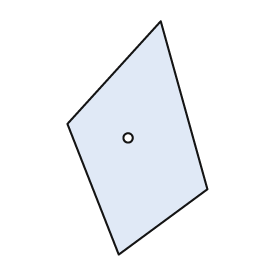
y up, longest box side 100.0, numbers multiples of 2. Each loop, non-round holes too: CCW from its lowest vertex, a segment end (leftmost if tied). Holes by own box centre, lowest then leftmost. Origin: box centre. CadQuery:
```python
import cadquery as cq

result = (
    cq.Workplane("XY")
    .moveTo(-8.0, -50.0)
    .lineTo(30.0, -22.0)
    .lineTo(10.0, 50.0)
    .lineTo(-30.0, 6.0)
    .close()
    .moveTo(-4.0, 0.0)
    .circle(2.0)
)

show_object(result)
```